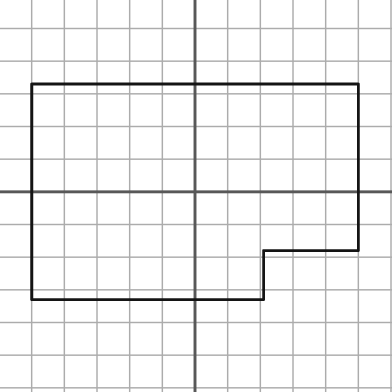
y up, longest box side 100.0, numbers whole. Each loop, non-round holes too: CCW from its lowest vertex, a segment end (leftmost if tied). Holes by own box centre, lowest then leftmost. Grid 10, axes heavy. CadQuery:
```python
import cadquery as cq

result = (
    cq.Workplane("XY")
    .moveTo(-50.0, -33.0)
    .lineTo(21.0, -33.0)
    .lineTo(21.0, -18.0)
    .lineTo(50.0, -18.0)
    .lineTo(50.0, 33.0)
    .lineTo(-50.0, 33.0)
    .close()
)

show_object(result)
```